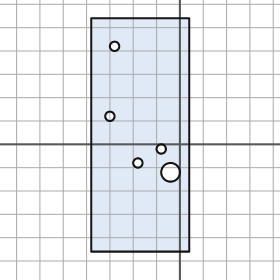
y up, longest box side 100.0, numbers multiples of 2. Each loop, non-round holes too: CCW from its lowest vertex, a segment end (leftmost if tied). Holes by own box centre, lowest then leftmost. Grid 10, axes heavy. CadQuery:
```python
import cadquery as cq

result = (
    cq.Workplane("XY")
    .moveTo(-38.0, -46.0)
    .lineTo(4.0, -46.0)
    .lineTo(4.0, 54.0)
    .lineTo(-38.0, 54.0)
    .close()
    .moveTo(-4.0, -12.0)
    .circle(4.0)
    .moveTo(-18.0, -8.0)
    .circle(2.0)
    .moveTo(-8.0, -2.0)
    .circle(2.0)
    .moveTo(-30.0, 12.0)
    .circle(2.0)
    .moveTo(-28.0, 42.0)
    .circle(2.0)
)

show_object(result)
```